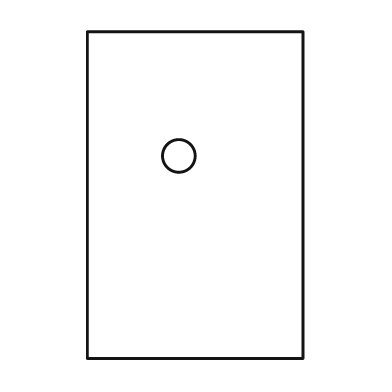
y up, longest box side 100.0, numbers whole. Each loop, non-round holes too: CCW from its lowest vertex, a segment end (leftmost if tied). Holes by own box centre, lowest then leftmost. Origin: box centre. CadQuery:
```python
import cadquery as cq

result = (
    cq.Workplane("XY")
    .moveTo(-33.0, -50.0)
    .lineTo(33.0, -50.0)
    .lineTo(33.0, 50.0)
    .lineTo(-33.0, 50.0)
    .close()
    .moveTo(-5.0, 12.0)
    .circle(5.0)
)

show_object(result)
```